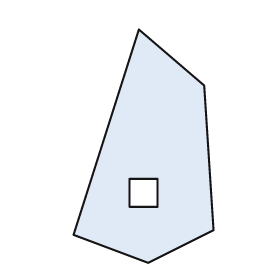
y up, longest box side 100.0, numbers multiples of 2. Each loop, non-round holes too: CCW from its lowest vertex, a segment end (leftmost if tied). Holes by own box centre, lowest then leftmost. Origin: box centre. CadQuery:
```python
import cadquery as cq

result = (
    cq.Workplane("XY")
    .moveTo(2.0, -50.0)
    .lineTo(30.0, -36.0)
    .lineTo(26.0, 26.0)
    .lineTo(-2.0, 50.0)
    .lineTo(-30.0, -38.0)
    .close()
    .moveTo(-6.0, -26.0)
    .lineTo(6.0, -26.0)
    .lineTo(6.0, -14.0)
    .lineTo(-6.0, -14.0)
    .close()
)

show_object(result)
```